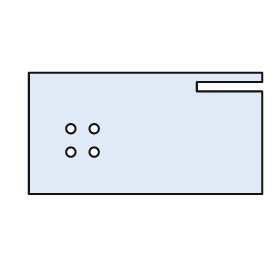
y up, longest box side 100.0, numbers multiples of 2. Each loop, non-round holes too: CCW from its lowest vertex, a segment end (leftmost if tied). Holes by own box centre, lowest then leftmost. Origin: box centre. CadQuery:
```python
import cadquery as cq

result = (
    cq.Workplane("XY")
    .moveTo(-50.0, -26.0)
    .lineTo(50.0, -26.0)
    .lineTo(50.0, 18.0)
    .lineTo(22.0, 18.0)
    .lineTo(22.0, 22.0)
    .lineTo(50.0, 22.0)
    .lineTo(50.0, 26.0)
    .lineTo(-50.0, 26.0)
    .close()
    .moveTo(-32.0, -8.0)
    .circle(2.0)
    .moveTo(-22.0, -8.0)
    .circle(2.0)
    .moveTo(-32.0, 2.0)
    .circle(2.0)
    .moveTo(-22.0, 2.0)
    .circle(2.0)
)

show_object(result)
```